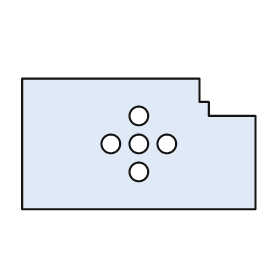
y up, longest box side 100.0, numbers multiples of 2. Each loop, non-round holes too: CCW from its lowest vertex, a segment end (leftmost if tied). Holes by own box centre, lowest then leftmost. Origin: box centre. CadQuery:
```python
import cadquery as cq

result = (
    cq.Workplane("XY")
    .moveTo(-50.0, -28.0)
    .lineTo(50.0, -28.0)
    .lineTo(50.0, 12.0)
    .lineTo(30.0, 12.0)
    .lineTo(30.0, 18.0)
    .lineTo(26.0, 18.0)
    .lineTo(26.0, 28.0)
    .lineTo(-50.0, 28.0)
    .close()
    .moveTo(0.0, -12.0)
    .circle(4.0)
    .moveTo(-12.0, 0.0)
    .circle(4.0)
    .moveTo(0.0, 0.0)
    .circle(4.0)
    .moveTo(12.0, 0.0)
    .circle(4.0)
    .moveTo(0.0, 12.0)
    .circle(4.0)
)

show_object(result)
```